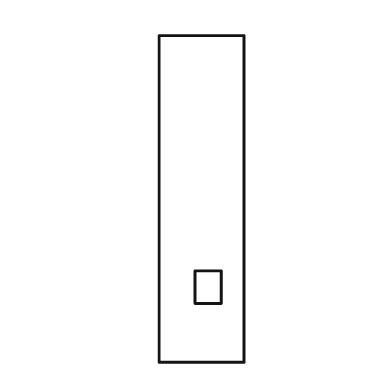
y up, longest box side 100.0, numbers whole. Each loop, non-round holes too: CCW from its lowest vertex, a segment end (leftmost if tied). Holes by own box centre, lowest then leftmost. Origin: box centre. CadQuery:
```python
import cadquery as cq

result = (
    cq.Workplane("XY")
    .moveTo(-13.0, -50.0)
    .lineTo(13.0, -50.0)
    .lineTo(13.0, 50.0)
    .lineTo(-13.0, 50.0)
    .close()
    .moveTo(-2.0, -32.0)
    .lineTo(6.0, -32.0)
    .lineTo(6.0, -22.0)
    .lineTo(-2.0, -22.0)
    .close()
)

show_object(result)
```